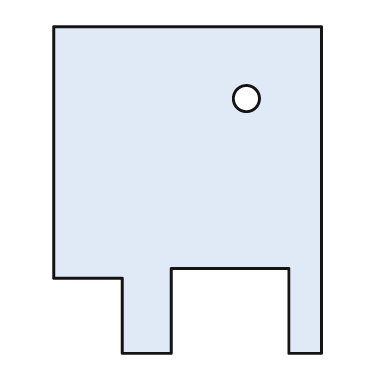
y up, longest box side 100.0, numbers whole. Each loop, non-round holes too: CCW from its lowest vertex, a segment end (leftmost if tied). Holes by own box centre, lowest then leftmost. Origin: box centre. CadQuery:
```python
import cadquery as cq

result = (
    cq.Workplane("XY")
    .moveTo(-20.0, -50.0)
    .lineTo(-5.0, -50.0)
    .lineTo(-5.0, -24.0)
    .lineTo(31.0, -24.0)
    .lineTo(31.0, -50.0)
    .lineTo(41.0, -50.0)
    .lineTo(41.0, 50.0)
    .lineTo(-41.0, 50.0)
    .lineTo(-41.0, -27.0)
    .lineTo(-20.0, -27.0)
    .close()
    .moveTo(18.0, 28.0)
    .circle(4.0)
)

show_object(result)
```